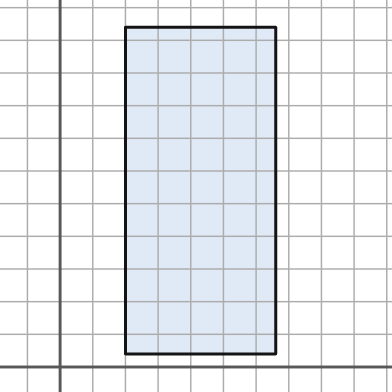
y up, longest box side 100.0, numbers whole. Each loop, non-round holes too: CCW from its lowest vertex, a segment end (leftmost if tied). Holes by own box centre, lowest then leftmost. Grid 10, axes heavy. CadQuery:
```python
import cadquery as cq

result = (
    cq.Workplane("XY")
    .moveTo(20.0, 4.0)
    .lineTo(66.0, 4.0)
    .lineTo(66.0, 104.0)
    .lineTo(20.0, 104.0)
    .close()
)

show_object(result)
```